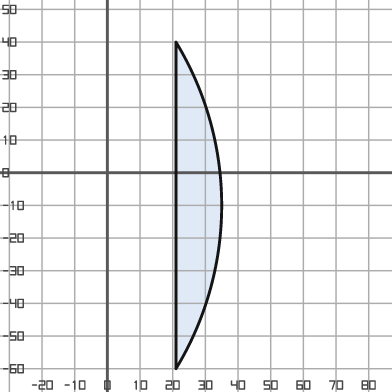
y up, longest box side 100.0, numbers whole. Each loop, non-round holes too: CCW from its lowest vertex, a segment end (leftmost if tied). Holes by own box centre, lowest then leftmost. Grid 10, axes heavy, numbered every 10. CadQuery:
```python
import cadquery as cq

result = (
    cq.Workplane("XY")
    .moveTo(21.0, -60.0)
    .threePointArc((35.0, -10.0), (21.0, 40.0))
    .close()
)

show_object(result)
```